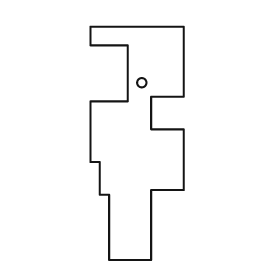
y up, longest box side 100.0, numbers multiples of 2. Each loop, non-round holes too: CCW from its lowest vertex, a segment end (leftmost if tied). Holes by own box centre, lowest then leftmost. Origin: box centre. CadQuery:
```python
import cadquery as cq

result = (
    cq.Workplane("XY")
    .moveTo(-12.0, -50.0)
    .lineTo(6.0, -50.0)
    .lineTo(6.0, -20.0)
    .lineTo(20.0, -20.0)
    .lineTo(20.0, 6.0)
    .lineTo(6.0, 6.0)
    .lineTo(6.0, 20.0)
    .lineTo(20.0, 20.0)
    .lineTo(20.0, 50.0)
    .lineTo(-20.0, 50.0)
    .lineTo(-20.0, 42.0)
    .lineTo(-4.0, 42.0)
    .lineTo(-4.0, 18.0)
    .lineTo(-20.0, 18.0)
    .lineTo(-20.0, -8.0)
    .lineTo(-16.0, -8.0)
    .lineTo(-16.0, -22.0)
    .lineTo(-12.0, -22.0)
    .close()
    .moveTo(2.0, 26.0)
    .circle(2.0)
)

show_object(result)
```